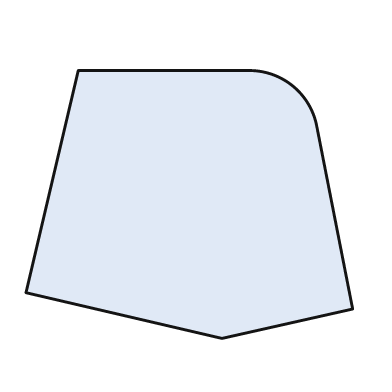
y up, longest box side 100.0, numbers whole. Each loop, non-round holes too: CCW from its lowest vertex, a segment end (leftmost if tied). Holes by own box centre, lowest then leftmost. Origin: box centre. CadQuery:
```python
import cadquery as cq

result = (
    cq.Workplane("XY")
    .moveTo(10.0, -41.0)
    .lineTo(50.0, -32.0)
    .lineTo(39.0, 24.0)
    .threePointArc((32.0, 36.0), (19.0, 41.0))
    .lineTo(-34.0, 41.0)
    .lineTo(-50.0, -27.0)
    .close()
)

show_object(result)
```